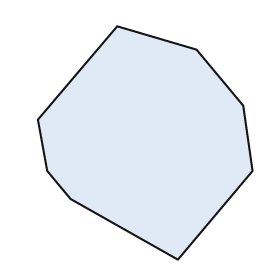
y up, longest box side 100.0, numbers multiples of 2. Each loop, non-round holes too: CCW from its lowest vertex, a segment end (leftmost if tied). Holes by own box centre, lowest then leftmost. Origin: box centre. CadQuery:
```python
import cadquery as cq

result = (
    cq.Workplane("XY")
    .moveTo(14.0, -50.0)
    .lineTo(46.0, -12.0)
    .lineTo(42.0, 16.0)
    .lineTo(22.0, 40.0)
    .lineTo(-12.0, 50.0)
    .lineTo(-46.0, 10.0)
    .lineTo(-42.0, -12.0)
    .lineTo(-32.0, -24.0)
    .close()
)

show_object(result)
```